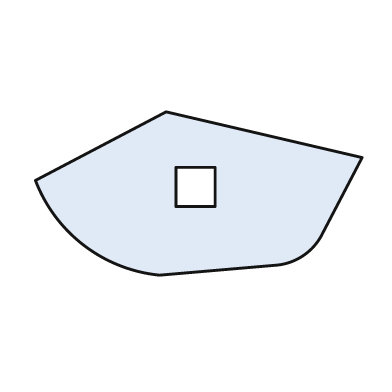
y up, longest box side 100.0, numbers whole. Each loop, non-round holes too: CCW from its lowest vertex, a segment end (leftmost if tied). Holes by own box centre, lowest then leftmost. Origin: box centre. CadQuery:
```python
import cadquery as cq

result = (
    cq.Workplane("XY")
    .moveTo(-12.0, -25.0)
    .lineTo(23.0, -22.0)
    .threePointArc((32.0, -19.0), (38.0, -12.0))
    .lineTo(50.0, 11.0)
    .lineTo(-10.0, 25.0)
    .lineTo(-50.0, 4.0)
    .threePointArc((-35.0, -16.0), (-12.0, -25.0))
    .close()
    .moveTo(-7.0, -4.0)
    .lineTo(5.0, -4.0)
    .lineTo(5.0, 8.0)
    .lineTo(-7.0, 8.0)
    .close()
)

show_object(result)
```